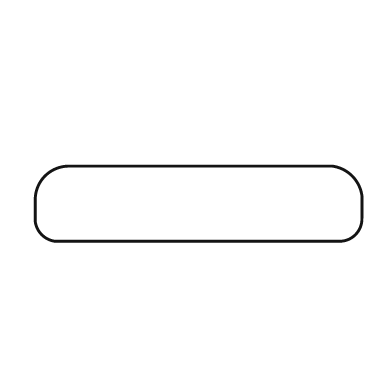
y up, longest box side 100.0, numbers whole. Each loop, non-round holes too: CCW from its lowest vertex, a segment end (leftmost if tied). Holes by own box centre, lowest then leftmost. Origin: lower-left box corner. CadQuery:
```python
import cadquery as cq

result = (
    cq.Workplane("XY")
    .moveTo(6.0, 0.0)
    .lineTo(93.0, 0.0)
    .threePointArc((98.0, 2.0), (100.0, 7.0))
    .lineTo(100.0, 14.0)
    .threePointArc((97.0, 20.0), (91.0, 23.0))
    .lineTo(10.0, 23.0)
    .threePointArc((3.0, 20.0), (0.0, 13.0))
    .lineTo(0.0, 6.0)
    .threePointArc((2.0, 2.0), (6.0, 0.0))
    .close()
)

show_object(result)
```